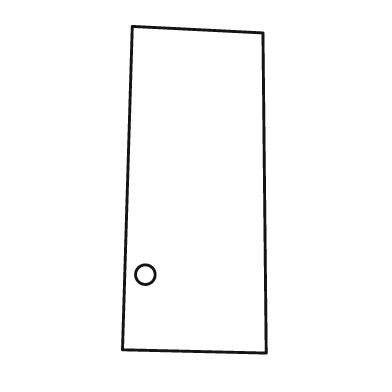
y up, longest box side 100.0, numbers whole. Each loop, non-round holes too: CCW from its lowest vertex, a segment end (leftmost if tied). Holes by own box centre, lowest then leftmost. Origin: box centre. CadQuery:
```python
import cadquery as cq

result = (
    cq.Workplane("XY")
    .moveTo(22.0, -50.0)
    .lineTo(21.0, 48.0)
    .lineTo(-19.0, 50.0)
    .lineTo(-22.0, -49.0)
    .close()
    .moveTo(-15.0, -26.0)
    .circle(3.0)
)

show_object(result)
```